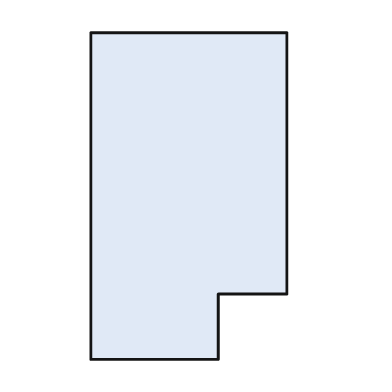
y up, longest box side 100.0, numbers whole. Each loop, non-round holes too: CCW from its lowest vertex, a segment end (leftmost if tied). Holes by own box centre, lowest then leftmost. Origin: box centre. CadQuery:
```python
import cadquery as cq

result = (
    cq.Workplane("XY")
    .moveTo(-30.0, -50.0)
    .lineTo(9.0, -50.0)
    .lineTo(9.0, -30.0)
    .lineTo(30.0, -30.0)
    .lineTo(30.0, 50.0)
    .lineTo(-30.0, 50.0)
    .close()
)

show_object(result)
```